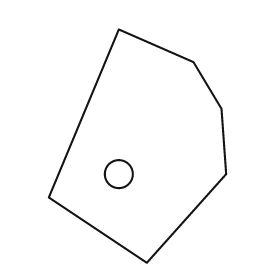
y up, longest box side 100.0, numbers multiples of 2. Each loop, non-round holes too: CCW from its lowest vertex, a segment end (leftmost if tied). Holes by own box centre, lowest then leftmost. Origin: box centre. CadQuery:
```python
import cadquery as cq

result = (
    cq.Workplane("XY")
    .moveTo(4.0, -50.0)
    .lineTo(38.0, -12.0)
    .lineTo(36.0, 16.0)
    .lineTo(24.0, 36.0)
    .lineTo(-8.0, 50.0)
    .lineTo(-38.0, -22.0)
    .close()
    .moveTo(-8.0, -12.0)
    .circle(6.0)
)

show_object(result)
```